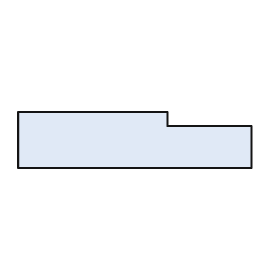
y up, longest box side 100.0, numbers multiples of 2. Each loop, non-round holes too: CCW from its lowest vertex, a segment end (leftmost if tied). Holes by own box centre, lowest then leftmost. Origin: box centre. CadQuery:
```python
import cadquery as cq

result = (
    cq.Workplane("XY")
    .moveTo(-50.0, -12.0)
    .lineTo(50.0, -12.0)
    .lineTo(50.0, 6.0)
    .lineTo(14.0, 6.0)
    .lineTo(14.0, 12.0)
    .lineTo(-50.0, 12.0)
    .close()
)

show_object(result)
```